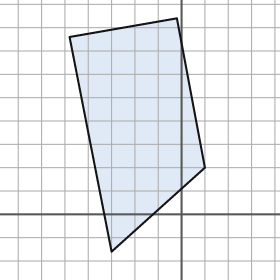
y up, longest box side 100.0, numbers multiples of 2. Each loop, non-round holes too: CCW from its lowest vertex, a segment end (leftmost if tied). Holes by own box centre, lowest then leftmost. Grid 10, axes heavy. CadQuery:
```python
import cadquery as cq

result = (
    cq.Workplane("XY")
    .moveTo(-30.0, -16.0)
    .lineTo(10.0, 20.0)
    .lineTo(-2.0, 84.0)
    .lineTo(-48.0, 76.0)
    .close()
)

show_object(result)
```